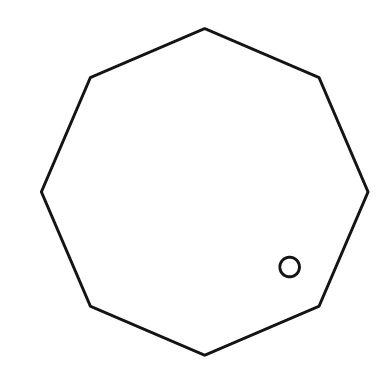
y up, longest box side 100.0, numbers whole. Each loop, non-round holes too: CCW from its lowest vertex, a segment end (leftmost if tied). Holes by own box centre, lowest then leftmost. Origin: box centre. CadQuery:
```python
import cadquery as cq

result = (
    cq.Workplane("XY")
    .moveTo(0.0, -50.0)
    .lineTo(35.0, -35.0)
    .lineTo(50.0, 0.0)
    .lineTo(35.0, 35.0)
    .lineTo(0.0, 50.0)
    .lineTo(-35.0, 35.0)
    .lineTo(-50.0, 0.0)
    .lineTo(-35.0, -35.0)
    .close()
    .moveTo(26.0, -23.0)
    .circle(3.0)
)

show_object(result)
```